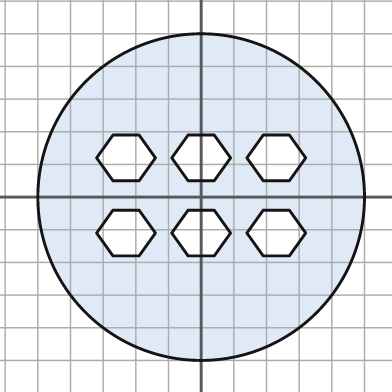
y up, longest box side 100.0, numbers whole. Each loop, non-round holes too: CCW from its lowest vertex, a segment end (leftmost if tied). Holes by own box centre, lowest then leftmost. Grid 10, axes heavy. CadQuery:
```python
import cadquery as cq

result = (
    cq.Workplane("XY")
    .moveTo(0.0, 0.0)
    .circle(50.0)
    .moveTo(-27.0, -18.0)
    .lineTo(-19.0, -18.0)
    .lineTo(-14.0, -11.0)
    .lineTo(-19.0, -4.0)
    .lineTo(-27.0, -4.0)
    .lineTo(-32.0, -11.0)
    .close()
    .moveTo(-4.0, -18.0)
    .lineTo(4.0, -18.0)
    .lineTo(9.0, -11.0)
    .lineTo(4.0, -4.0)
    .lineTo(-4.0, -4.0)
    .lineTo(-9.0, -11.0)
    .close()
    .moveTo(19.0, -18.0)
    .lineTo(27.0, -18.0)
    .lineTo(32.0, -11.0)
    .lineTo(27.0, -4.0)
    .lineTo(19.0, -4.0)
    .lineTo(14.0, -11.0)
    .close()
    .moveTo(-27.0, 5.0)
    .lineTo(-19.0, 5.0)
    .lineTo(-14.0, 12.0)
    .lineTo(-19.0, 19.0)
    .lineTo(-27.0, 19.0)
    .lineTo(-32.0, 12.0)
    .close()
    .moveTo(-4.0, 5.0)
    .lineTo(4.0, 5.0)
    .lineTo(9.0, 12.0)
    .lineTo(4.0, 19.0)
    .lineTo(-4.0, 19.0)
    .lineTo(-9.0, 12.0)
    .close()
    .moveTo(19.0, 5.0)
    .lineTo(27.0, 5.0)
    .lineTo(32.0, 12.0)
    .lineTo(27.0, 19.0)
    .lineTo(19.0, 19.0)
    .lineTo(14.0, 12.0)
    .close()
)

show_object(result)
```